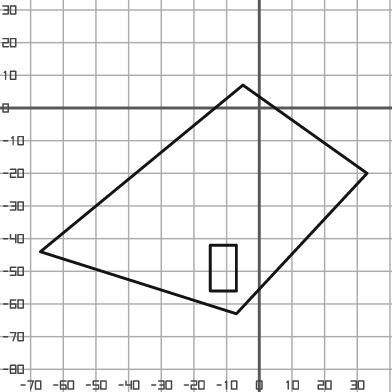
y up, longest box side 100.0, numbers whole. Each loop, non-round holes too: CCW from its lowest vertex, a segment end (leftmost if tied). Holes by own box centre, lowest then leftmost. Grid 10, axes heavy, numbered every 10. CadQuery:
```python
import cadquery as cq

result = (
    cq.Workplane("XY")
    .moveTo(-7.0, -63.0)
    .lineTo(33.0, -20.0)
    .lineTo(-5.0, 7.0)
    .lineTo(-67.0, -44.0)
    .close()
    .moveTo(-15.0, -56.0)
    .lineTo(-7.0, -56.0)
    .lineTo(-7.0, -42.0)
    .lineTo(-15.0, -42.0)
    .close()
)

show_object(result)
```